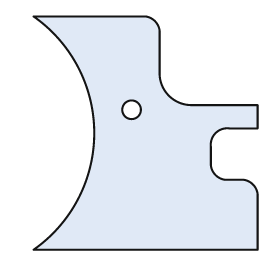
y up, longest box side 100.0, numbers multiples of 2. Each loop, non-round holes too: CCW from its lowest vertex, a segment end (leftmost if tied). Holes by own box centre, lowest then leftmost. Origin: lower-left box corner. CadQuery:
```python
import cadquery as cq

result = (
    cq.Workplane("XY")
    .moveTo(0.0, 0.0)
    .lineTo(96.0, 0.0)
    .lineTo(96.0, 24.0)
    .threePointArc((94.0, 28.0), (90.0, 30.0))
    .lineTo(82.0, 30.0)
    .threePointArc((78.0, 32.0), (76.0, 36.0))
    .lineTo(76.0, 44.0)
    .threePointArc((78.0, 50.0), (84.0, 52.0))
    .lineTo(96.0, 52.0)
    .lineTo(96.0, 62.0)
    .lineTo(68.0, 62.0)
    .threePointArc((58.0, 66.0), (54.0, 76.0))
    .lineTo(54.0, 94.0)
    .threePointArc((52.0, 98.0), (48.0, 100.0))
    .lineTo(0.0, 100.0)
    .threePointArc((26.0, 50.0), (0.0, 0.0))
    .close()
    .moveTo(42.0, 60.0)
    .circle(4.0)
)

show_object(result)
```